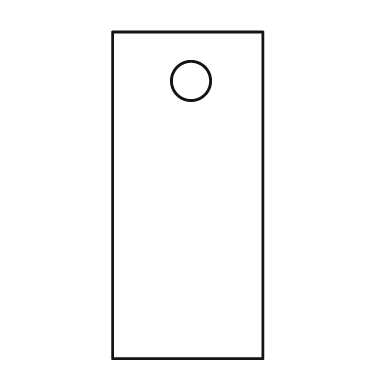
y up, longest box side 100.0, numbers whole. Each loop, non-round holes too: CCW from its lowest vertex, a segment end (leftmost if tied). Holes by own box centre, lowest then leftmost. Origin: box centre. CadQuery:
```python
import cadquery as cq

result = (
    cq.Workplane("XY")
    .moveTo(-23.0, -50.0)
    .lineTo(23.0, -50.0)
    .lineTo(23.0, 50.0)
    .lineTo(-23.0, 50.0)
    .close()
    .moveTo(1.0, 35.0)
    .circle(6.0)
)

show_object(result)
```